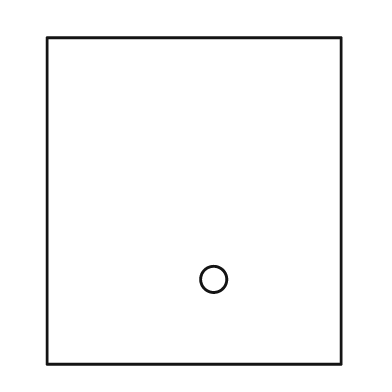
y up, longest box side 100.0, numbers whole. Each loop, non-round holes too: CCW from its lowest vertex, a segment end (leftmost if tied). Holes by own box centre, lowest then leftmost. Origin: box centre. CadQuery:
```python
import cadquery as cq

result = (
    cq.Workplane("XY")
    .moveTo(-45.0, -50.0)
    .lineTo(45.0, -50.0)
    .lineTo(45.0, 50.0)
    .lineTo(-45.0, 50.0)
    .close()
    .moveTo(6.0, -24.0)
    .circle(4.0)
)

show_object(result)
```